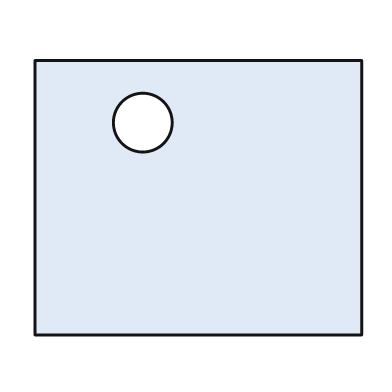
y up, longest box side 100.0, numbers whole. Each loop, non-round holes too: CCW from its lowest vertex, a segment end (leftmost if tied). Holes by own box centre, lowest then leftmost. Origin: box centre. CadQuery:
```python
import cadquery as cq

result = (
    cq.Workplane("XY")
    .moveTo(-50.0, -42.0)
    .lineTo(50.0, -42.0)
    .lineTo(50.0, 42.0)
    .lineTo(-50.0, 42.0)
    .close()
    .moveTo(-17.0, 23.0)
    .circle(9.0)
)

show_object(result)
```